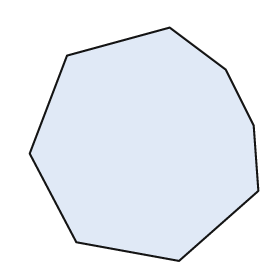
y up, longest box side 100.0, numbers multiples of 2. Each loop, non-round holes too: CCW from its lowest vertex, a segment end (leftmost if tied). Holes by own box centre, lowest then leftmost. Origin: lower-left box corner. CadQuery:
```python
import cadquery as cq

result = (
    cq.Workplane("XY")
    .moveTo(64.0, 0.0)
    .lineTo(98.0, 30.0)
    .lineTo(96.0, 58.0)
    .lineTo(84.0, 82.0)
    .lineTo(60.0, 100.0)
    .lineTo(16.0, 88.0)
    .lineTo(0.0, 46.0)
    .lineTo(20.0, 8.0)
    .close()
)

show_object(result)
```